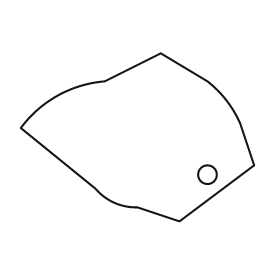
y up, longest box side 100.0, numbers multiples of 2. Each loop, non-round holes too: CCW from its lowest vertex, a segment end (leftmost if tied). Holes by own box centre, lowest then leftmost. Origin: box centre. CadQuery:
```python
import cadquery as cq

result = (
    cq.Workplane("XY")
    .moveTo(18.0, -36.0)
    .lineTo(50.0, -12.0)
    .lineTo(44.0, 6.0)
    .threePointArc((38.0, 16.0), (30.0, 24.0))
    .lineTo(10.0, 36.0)
    .lineTo(-14.0, 24.0)
    .threePointArc((-34.0, 18.0), (-50.0, 4.0))
    .lineTo(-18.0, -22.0)
    .threePointArc((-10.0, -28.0), (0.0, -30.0))
    .close()
    .moveTo(30.0, -16.0)
    .circle(4.0)
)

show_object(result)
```